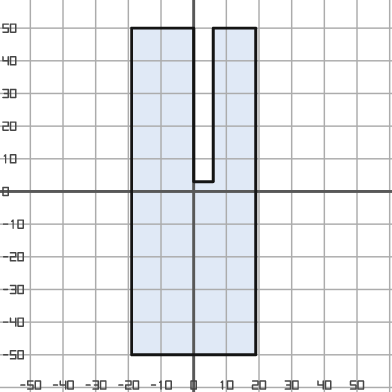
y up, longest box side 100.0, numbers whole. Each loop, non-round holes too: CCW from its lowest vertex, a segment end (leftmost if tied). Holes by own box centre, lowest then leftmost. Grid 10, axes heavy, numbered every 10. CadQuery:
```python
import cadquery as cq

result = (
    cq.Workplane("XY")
    .moveTo(-19.0, -50.0)
    .lineTo(19.0, -50.0)
    .lineTo(19.0, 50.0)
    .lineTo(6.0, 50.0)
    .lineTo(6.0, 3.0)
    .lineTo(0.0, 3.0)
    .lineTo(0.0, 50.0)
    .lineTo(-19.0, 50.0)
    .close()
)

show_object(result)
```